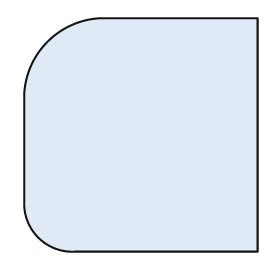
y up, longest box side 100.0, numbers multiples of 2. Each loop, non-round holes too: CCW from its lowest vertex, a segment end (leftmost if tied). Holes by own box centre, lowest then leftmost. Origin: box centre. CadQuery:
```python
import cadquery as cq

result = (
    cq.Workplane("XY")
    .moveTo(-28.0, -50.0)
    .lineTo(50.0, -50.0)
    .lineTo(50.0, 50.0)
    .lineTo(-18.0, 50.0)
    .threePointArc((-40.0, 40.0), (-50.0, 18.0))
    .lineTo(-50.0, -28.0)
    .threePointArc((-44.0, -44.0), (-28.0, -50.0))
    .close()
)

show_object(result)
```